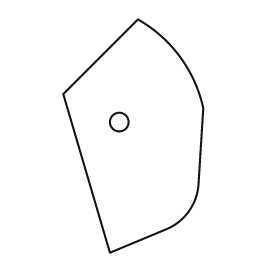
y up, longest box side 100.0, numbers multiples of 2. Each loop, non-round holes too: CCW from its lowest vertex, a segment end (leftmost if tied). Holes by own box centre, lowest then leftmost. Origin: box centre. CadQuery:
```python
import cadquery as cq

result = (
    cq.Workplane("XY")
    .moveTo(-10.0, -50.0)
    .lineTo(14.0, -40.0)
    .threePointArc((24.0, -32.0), (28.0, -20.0))
    .lineTo(30.0, 12.0)
    .threePointArc((20.0, 34.0), (2.0, 50.0))
    .lineTo(-30.0, 18.0)
    .close()
    .moveTo(-6.0, 6.0)
    .circle(4.0)
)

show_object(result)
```